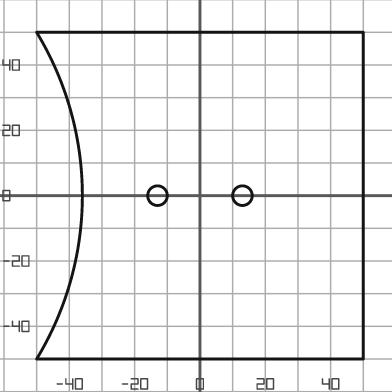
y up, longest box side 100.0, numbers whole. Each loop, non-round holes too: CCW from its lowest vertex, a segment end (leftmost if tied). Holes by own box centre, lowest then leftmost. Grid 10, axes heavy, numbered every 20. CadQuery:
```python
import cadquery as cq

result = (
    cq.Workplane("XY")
    .moveTo(-50.0, -50.0)
    .lineTo(50.0, -50.0)
    .lineTo(50.0, 50.0)
    .lineTo(-50.0, 50.0)
    .threePointArc((-36.0, 0.0), (-50.0, -50.0))
    .close()
    .moveTo(-13.0, 0.0)
    .circle(3.0)
    .moveTo(13.0, 0.0)
    .circle(3.0)
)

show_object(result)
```